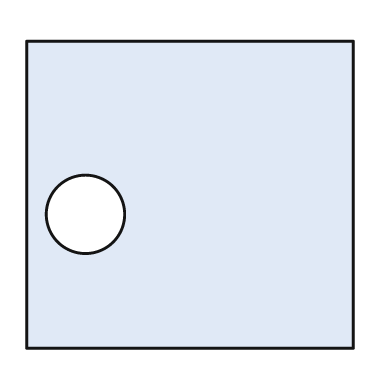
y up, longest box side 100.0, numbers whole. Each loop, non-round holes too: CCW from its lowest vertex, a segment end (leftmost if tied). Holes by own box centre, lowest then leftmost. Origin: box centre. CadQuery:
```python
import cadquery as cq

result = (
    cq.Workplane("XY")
    .moveTo(-50.0, -47.0)
    .lineTo(50.0, -47.0)
    .lineTo(50.0, 47.0)
    .lineTo(-50.0, 47.0)
    .close()
    .moveTo(-32.0, -6.0)
    .circle(12.0)
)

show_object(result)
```